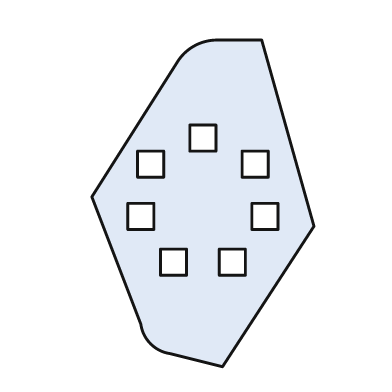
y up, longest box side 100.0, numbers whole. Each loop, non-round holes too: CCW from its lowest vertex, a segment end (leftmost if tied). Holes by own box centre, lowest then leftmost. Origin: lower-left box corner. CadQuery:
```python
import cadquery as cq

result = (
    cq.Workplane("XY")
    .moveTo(40.0, 0.0)
    .lineTo(68.0, 43.0)
    .lineTo(52.0, 100.0)
    .lineTo(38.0, 100.0)
    .threePointArc((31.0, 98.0), (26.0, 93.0))
    .lineTo(0.0, 52.0)
    .lineTo(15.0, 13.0)
    .threePointArc((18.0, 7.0), (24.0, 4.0))
    .close()
    .moveTo(21.0, 28.0)
    .lineTo(29.0, 28.0)
    .lineTo(29.0, 36.0)
    .lineTo(21.0, 36.0)
    .close()
    .moveTo(39.0, 28.0)
    .lineTo(47.0, 28.0)
    .lineTo(47.0, 36.0)
    .lineTo(39.0, 36.0)
    .close()
    .moveTo(11.0, 42.0)
    .lineTo(19.0, 42.0)
    .lineTo(19.0, 50.0)
    .lineTo(11.0, 50.0)
    .close()
    .moveTo(49.0, 42.0)
    .lineTo(57.0, 42.0)
    .lineTo(57.0, 50.0)
    .lineTo(49.0, 50.0)
    .close()
    .moveTo(14.0, 58.0)
    .lineTo(22.0, 58.0)
    .lineTo(22.0, 66.0)
    .lineTo(14.0, 66.0)
    .close()
    .moveTo(46.0, 58.0)
    .lineTo(54.0, 58.0)
    .lineTo(54.0, 66.0)
    .lineTo(46.0, 66.0)
    .close()
    .moveTo(30.0, 66.0)
    .lineTo(38.0, 66.0)
    .lineTo(38.0, 74.0)
    .lineTo(30.0, 74.0)
    .close()
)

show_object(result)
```